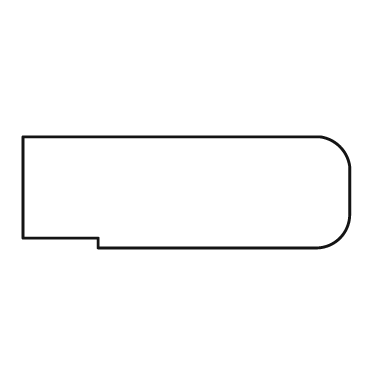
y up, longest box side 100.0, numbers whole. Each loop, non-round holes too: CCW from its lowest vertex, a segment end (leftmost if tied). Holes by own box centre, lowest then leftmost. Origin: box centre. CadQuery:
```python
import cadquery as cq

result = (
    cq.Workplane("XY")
    .moveTo(-27.0, -17.0)
    .lineTo(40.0, -17.0)
    .threePointArc((47.0, -14.0), (50.0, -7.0))
    .lineTo(50.0, 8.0)
    .threePointArc((47.0, 14.0), (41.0, 17.0))
    .lineTo(-50.0, 17.0)
    .lineTo(-50.0, -14.0)
    .lineTo(-27.0, -14.0)
    .close()
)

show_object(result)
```